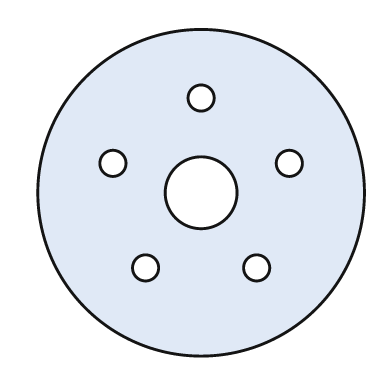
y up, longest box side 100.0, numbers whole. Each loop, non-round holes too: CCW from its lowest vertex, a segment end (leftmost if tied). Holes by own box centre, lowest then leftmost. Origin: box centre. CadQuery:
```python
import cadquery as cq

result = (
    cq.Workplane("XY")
    .moveTo(0.0, 0.0)
    .circle(50.0)
    .moveTo(-17.0, -23.0)
    .circle(4.0)
    .moveTo(17.0, -23.0)
    .circle(4.0)
    .moveTo(0.0, 0.0)
    .circle(11.0)
    .moveTo(-27.0, 9.0)
    .circle(4.0)
    .moveTo(27.0, 9.0)
    .circle(4.0)
    .moveTo(0.0, 29.0)
    .circle(4.0)
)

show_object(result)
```